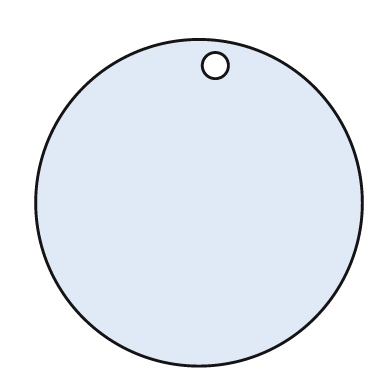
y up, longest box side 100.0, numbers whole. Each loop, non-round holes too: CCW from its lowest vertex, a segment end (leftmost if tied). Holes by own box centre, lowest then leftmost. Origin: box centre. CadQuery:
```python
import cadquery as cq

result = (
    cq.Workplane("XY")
    .moveTo(0.0, 0.0)
    .circle(50.0)
    .moveTo(5.0, 42.0)
    .circle(4.0)
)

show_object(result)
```